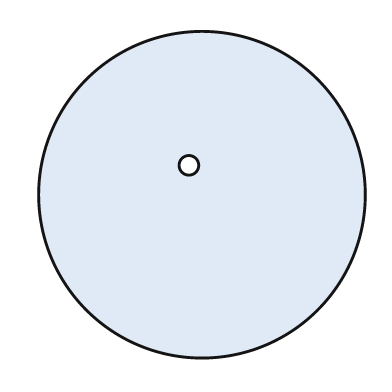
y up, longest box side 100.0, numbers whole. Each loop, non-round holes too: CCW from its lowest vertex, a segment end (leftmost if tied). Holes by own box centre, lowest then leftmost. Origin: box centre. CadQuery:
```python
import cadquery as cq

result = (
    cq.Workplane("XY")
    .moveTo(0.0, 0.0)
    .circle(50.0)
    .moveTo(-4.0, 9.0)
    .circle(3.0)
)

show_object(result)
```